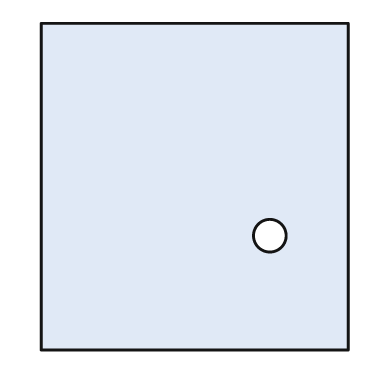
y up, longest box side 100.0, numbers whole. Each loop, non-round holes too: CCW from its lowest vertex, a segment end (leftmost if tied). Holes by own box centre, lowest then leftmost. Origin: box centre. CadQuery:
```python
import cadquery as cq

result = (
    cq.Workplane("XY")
    .moveTo(-47.0, -50.0)
    .lineTo(47.0, -50.0)
    .lineTo(47.0, 50.0)
    .lineTo(-47.0, 50.0)
    .close()
    .moveTo(23.0, -15.0)
    .circle(5.0)
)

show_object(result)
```